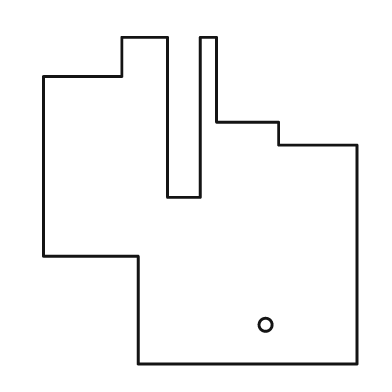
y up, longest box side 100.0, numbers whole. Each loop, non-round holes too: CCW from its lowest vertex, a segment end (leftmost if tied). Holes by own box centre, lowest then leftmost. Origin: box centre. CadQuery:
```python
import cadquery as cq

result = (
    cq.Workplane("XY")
    .moveTo(-19.0, -50.0)
    .lineTo(48.0, -50.0)
    .lineTo(48.0, 17.0)
    .lineTo(24.0, 17.0)
    .lineTo(24.0, 24.0)
    .lineTo(5.0, 24.0)
    .lineTo(5.0, 50.0)
    .lineTo(0.0, 50.0)
    .lineTo(0.0, 1.0)
    .lineTo(-10.0, 1.0)
    .lineTo(-10.0, 50.0)
    .lineTo(-24.0, 50.0)
    .lineTo(-24.0, 38.0)
    .lineTo(-48.0, 38.0)
    .lineTo(-48.0, -17.0)
    .lineTo(-19.0, -17.0)
    .close()
    .moveTo(20.0, -38.0)
    .circle(2.0)
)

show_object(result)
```